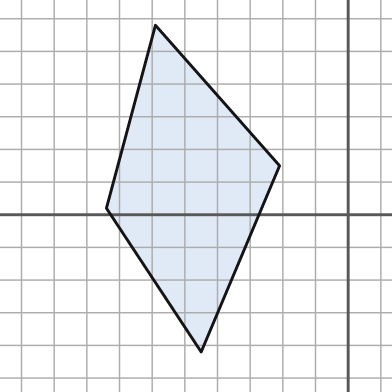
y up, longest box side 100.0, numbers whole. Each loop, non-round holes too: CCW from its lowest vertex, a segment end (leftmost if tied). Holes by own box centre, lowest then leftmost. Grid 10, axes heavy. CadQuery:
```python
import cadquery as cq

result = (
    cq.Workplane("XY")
    .moveTo(-45.0, -42.0)
    .lineTo(-21.0, 15.0)
    .lineTo(-59.0, 58.0)
    .lineTo(-74.0, 2.0)
    .close()
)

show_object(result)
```